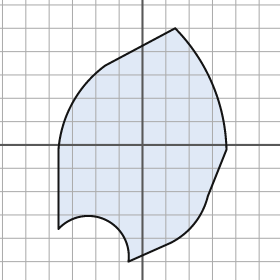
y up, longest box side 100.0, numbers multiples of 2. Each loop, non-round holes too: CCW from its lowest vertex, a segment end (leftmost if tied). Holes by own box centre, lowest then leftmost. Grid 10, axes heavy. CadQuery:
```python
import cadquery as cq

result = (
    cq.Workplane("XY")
    .moveTo(-6.0, -50.0)
    .lineTo(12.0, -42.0)
    .threePointArc((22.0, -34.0), (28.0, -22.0))
    .lineTo(36.0, -2.0)
    .threePointArc((30.0, 26.0), (14.0, 50.0))
    .lineTo(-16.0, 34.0)
    .threePointArc((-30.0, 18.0), (-36.0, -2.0))
    .lineTo(-36.0, -36.0)
    .threePointArc((-16.0, -32.0), (-6.0, -50.0))
    .close()
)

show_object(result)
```